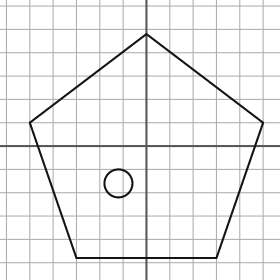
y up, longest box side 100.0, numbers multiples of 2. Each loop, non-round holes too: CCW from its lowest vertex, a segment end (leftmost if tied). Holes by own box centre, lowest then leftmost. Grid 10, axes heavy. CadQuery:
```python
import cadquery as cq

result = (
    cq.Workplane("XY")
    .moveTo(-30.0, -48.0)
    .lineTo(30.0, -48.0)
    .lineTo(50.0, 10.0)
    .lineTo(0.0, 48.0)
    .lineTo(-50.0, 10.0)
    .close()
    .moveTo(-12.0, -16.0)
    .circle(6.0)
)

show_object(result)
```